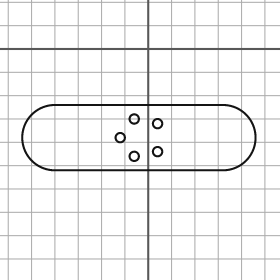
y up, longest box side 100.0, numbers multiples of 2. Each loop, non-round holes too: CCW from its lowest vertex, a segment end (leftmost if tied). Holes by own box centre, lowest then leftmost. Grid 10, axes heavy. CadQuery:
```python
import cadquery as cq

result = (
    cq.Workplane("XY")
    .moveTo(-40.0, -52.0)
    .lineTo(32.0, -52.0)
    .threePointArc((46.0, -38.0), (32.0, -24.0))
    .lineTo(-40.0, -24.0)
    .threePointArc((-54.0, -38.0), (-40.0, -52.0))
    .close()
    .moveTo(-6.0, -46.0)
    .circle(2.0)
    .moveTo(4.0, -44.0)
    .circle(2.0)
    .moveTo(-12.0, -38.0)
    .circle(2.0)
    .moveTo(4.0, -32.0)
    .circle(2.0)
    .moveTo(-6.0, -30.0)
    .circle(2.0)
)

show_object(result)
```